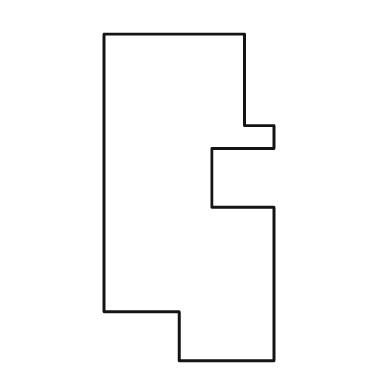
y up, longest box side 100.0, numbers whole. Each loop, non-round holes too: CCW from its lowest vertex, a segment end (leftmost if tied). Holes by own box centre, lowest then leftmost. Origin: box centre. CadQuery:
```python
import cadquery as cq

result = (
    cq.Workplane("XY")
    .moveTo(-3.0, -50.0)
    .lineTo(26.0, -50.0)
    .lineTo(26.0, -3.0)
    .lineTo(7.0, -3.0)
    .lineTo(7.0, 15.0)
    .lineTo(26.0, 15.0)
    .lineTo(26.0, 22.0)
    .lineTo(17.0, 22.0)
    .lineTo(17.0, 50.0)
    .lineTo(-26.0, 50.0)
    .lineTo(-26.0, -35.0)
    .lineTo(-3.0, -35.0)
    .close()
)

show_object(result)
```